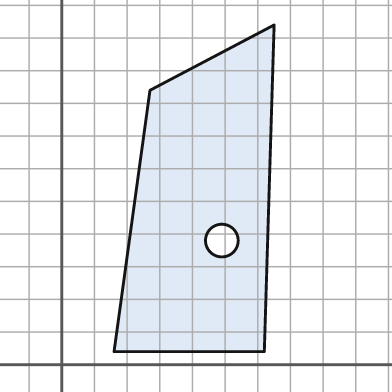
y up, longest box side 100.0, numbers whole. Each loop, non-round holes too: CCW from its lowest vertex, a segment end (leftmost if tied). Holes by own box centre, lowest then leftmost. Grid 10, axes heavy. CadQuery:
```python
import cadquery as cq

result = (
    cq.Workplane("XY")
    .moveTo(16.0, 4.0)
    .lineTo(62.0, 4.0)
    .lineTo(65.0, 104.0)
    .lineTo(27.0, 84.0)
    .close()
    .moveTo(49.0, 38.0)
    .circle(5.0)
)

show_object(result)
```